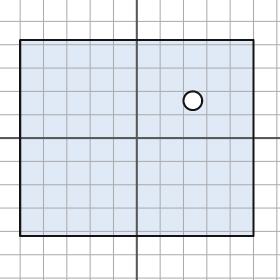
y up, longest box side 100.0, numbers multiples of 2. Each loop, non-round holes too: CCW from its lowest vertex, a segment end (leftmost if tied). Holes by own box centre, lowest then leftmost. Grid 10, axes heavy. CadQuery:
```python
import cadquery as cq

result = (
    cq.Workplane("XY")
    .moveTo(-50.0, -42.0)
    .lineTo(50.0, -42.0)
    .lineTo(50.0, 42.0)
    .lineTo(-50.0, 42.0)
    .close()
    .moveTo(24.0, 16.0)
    .circle(4.0)
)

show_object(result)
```